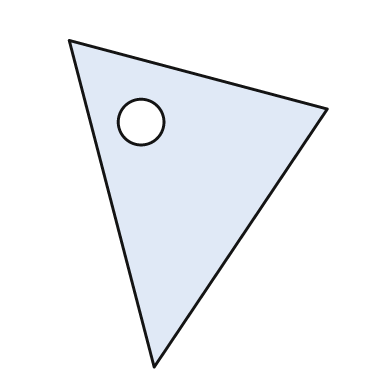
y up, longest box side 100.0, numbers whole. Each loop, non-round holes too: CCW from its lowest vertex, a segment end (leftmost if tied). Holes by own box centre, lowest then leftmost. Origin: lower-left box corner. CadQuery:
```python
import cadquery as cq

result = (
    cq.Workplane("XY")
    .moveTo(26.0, 0.0)
    .lineTo(79.0, 79.0)
    .lineTo(0.0, 100.0)
    .close()
    .moveTo(22.0, 75.0)
    .circle(7.0)
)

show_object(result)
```